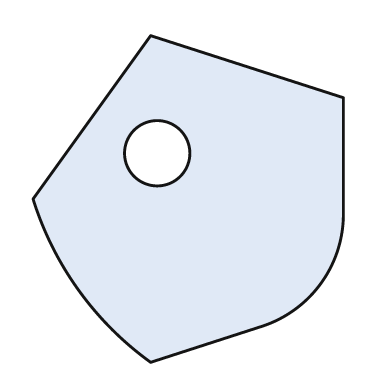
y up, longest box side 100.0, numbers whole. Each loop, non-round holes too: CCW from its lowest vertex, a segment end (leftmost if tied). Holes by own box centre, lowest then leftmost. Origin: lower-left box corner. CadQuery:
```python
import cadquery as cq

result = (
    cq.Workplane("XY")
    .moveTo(36.0, 0.0)
    .lineTo(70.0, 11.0)
    .threePointArc((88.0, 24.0), (95.0, 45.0))
    .lineTo(95.0, 81.0)
    .lineTo(36.0, 100.0)
    .lineTo(0.0, 50.0)
    .threePointArc((14.0, 22.0), (36.0, 0.0))
    .close()
    .moveTo(38.0, 64.0)
    .circle(10.0)
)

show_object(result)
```